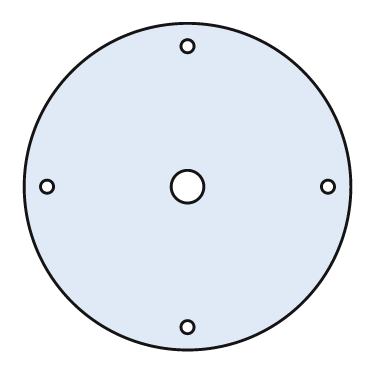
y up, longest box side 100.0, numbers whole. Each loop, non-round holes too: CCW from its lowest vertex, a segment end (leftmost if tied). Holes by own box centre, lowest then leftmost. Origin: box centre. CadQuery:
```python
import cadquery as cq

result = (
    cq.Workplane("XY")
    .moveTo(0.0, 0.0)
    .circle(50.0)
    .moveTo(0.0, -43.0)
    .circle(2.0)
    .moveTo(-43.0, 0.0)
    .circle(2.0)
    .moveTo(0.0, 0.0)
    .circle(5.0)
    .moveTo(43.0, 0.0)
    .circle(2.0)
    .moveTo(0.0, 43.0)
    .circle(2.0)
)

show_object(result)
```